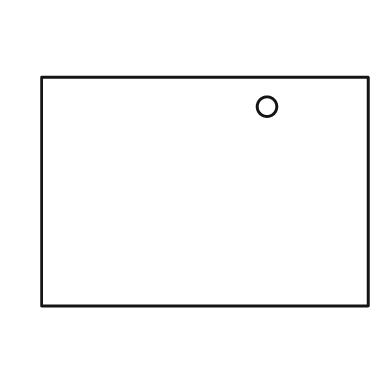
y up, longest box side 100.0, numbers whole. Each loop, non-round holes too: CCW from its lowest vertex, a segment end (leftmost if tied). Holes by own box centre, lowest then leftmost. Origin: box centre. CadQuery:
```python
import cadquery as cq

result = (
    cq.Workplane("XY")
    .moveTo(-50.0, -35.0)
    .lineTo(50.0, -35.0)
    .lineTo(50.0, 35.0)
    .lineTo(-50.0, 35.0)
    .close()
    .moveTo(19.0, 26.0)
    .circle(3.0)
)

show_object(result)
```